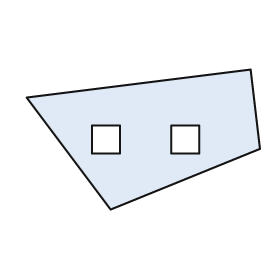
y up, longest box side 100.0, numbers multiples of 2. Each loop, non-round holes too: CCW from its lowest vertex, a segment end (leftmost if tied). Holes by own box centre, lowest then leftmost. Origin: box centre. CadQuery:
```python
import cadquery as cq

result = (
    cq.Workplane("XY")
    .moveTo(-14.0, -30.0)
    .lineTo(50.0, -4.0)
    .lineTo(46.0, 30.0)
    .lineTo(-50.0, 18.0)
    .close()
    .moveTo(-22.0, -6.0)
    .lineTo(-10.0, -6.0)
    .lineTo(-10.0, 6.0)
    .lineTo(-22.0, 6.0)
    .close()
    .moveTo(12.0, -6.0)
    .lineTo(24.0, -6.0)
    .lineTo(24.0, 6.0)
    .lineTo(12.0, 6.0)
    .close()
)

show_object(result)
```